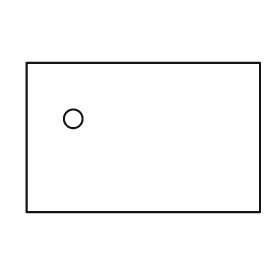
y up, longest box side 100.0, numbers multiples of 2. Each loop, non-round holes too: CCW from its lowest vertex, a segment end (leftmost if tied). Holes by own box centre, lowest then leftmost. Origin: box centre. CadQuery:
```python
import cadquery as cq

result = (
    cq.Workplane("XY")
    .moveTo(-50.0, -32.0)
    .lineTo(50.0, -32.0)
    .lineTo(50.0, 32.0)
    .lineTo(-50.0, 32.0)
    .close()
    .moveTo(-30.0, 8.0)
    .circle(4.0)
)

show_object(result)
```